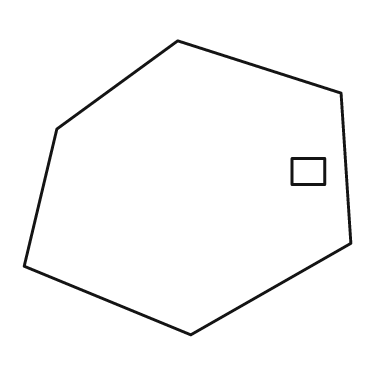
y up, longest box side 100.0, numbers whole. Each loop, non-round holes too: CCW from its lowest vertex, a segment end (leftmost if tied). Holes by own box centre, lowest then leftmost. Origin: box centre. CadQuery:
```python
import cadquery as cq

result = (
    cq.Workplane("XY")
    .moveTo(1.0, -45.0)
    .lineTo(50.0, -17.0)
    .lineTo(47.0, 29.0)
    .lineTo(-3.0, 45.0)
    .lineTo(-40.0, 18.0)
    .lineTo(-50.0, -24.0)
    .close()
    .moveTo(32.0, 1.0)
    .lineTo(42.0, 1.0)
    .lineTo(42.0, 9.0)
    .lineTo(32.0, 9.0)
    .close()
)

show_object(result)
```